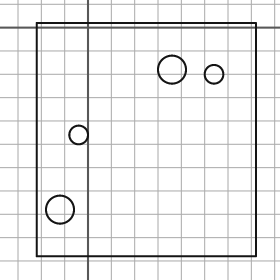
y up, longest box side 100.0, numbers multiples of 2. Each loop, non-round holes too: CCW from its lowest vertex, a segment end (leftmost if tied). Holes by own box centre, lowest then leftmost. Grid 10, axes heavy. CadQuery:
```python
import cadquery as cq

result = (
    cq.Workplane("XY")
    .moveTo(-22.0, -98.0)
    .lineTo(72.0, -98.0)
    .lineTo(72.0, 2.0)
    .lineTo(-22.0, 2.0)
    .close()
    .moveTo(-12.0, -78.0)
    .circle(6.0)
    .moveTo(-4.0, -46.0)
    .circle(4.0)
    .moveTo(54.0, -20.0)
    .circle(4.0)
    .moveTo(36.0, -18.0)
    .circle(6.0)
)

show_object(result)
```